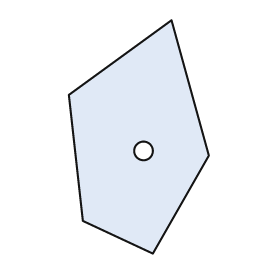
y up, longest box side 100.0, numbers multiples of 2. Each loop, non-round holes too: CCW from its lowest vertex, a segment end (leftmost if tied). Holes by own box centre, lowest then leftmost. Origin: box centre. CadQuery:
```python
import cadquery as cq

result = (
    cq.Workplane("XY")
    .moveTo(6.0, -50.0)
    .lineTo(30.0, -8.0)
    .lineTo(14.0, 50.0)
    .lineTo(-30.0, 18.0)
    .lineTo(-24.0, -36.0)
    .close()
    .moveTo(2.0, -6.0)
    .circle(4.0)
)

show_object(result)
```